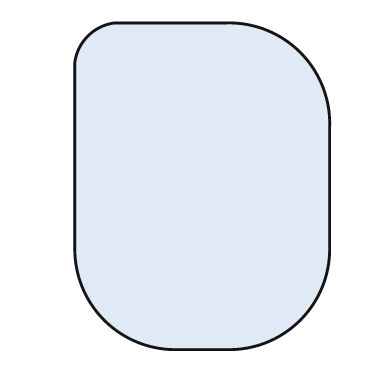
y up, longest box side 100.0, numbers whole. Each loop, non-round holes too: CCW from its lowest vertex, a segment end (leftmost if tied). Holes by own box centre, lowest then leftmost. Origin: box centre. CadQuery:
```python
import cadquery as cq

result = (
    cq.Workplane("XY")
    .moveTo(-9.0, -50.0)
    .lineTo(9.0, -50.0)
    .threePointArc((30.0, -41.0), (39.0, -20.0))
    .lineTo(39.0, 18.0)
    .threePointArc((30.0, 41.0), (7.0, 50.0))
    .lineTo(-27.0, 50.0)
    .threePointArc((-35.0, 46.0), (-39.0, 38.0))
    .lineTo(-39.0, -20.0)
    .threePointArc((-30.0, -41.0), (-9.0, -50.0))
    .close()
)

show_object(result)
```